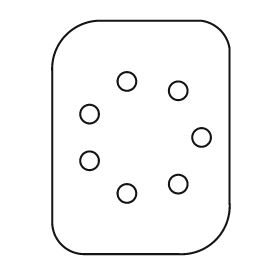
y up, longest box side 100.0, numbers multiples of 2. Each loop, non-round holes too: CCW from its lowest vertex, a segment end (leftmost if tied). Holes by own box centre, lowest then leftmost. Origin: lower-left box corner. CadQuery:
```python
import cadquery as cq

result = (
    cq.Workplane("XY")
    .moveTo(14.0, 0.0)
    .lineTo(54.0, 0.0)
    .threePointArc((70.0, 6.0), (76.0, 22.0))
    .lineTo(76.0, 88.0)
    .threePointArc((72.0, 96.0), (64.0, 100.0))
    .lineTo(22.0, 100.0)
    .threePointArc((6.0, 94.0), (0.0, 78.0))
    .lineTo(0.0, 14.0)
    .threePointArc((4.0, 4.0), (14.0, 0.0))
    .close()
    .moveTo(32.0, 26.0)
    .circle(4.0)
    .moveTo(54.0, 30.0)
    .circle(4.0)
    .moveTo(16.0, 40.0)
    .circle(4.0)
    .moveTo(64.0, 50.0)
    .circle(4.0)
    .moveTo(16.0, 60.0)
    .circle(4.0)
    .moveTo(54.0, 70.0)
    .circle(4.0)
    .moveTo(32.0, 74.0)
    .circle(4.0)
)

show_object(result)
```